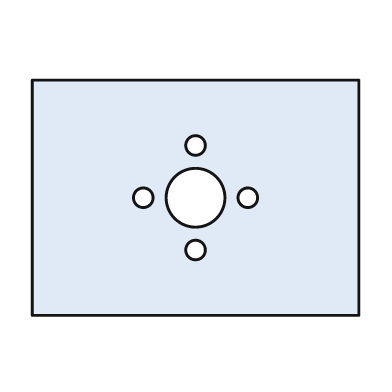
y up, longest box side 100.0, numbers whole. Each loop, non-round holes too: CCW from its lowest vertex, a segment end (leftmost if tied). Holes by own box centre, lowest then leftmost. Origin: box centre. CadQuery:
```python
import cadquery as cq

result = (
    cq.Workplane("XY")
    .moveTo(-50.0, -36.0)
    .lineTo(50.0, -36.0)
    .lineTo(50.0, 36.0)
    .lineTo(-50.0, 36.0)
    .close()
    .moveTo(0.0, -16.0)
    .circle(3.0)
    .moveTo(-16.0, 0.0)
    .circle(3.0)
    .moveTo(0.0, 0.0)
    .circle(9.0)
    .moveTo(16.0, 0.0)
    .circle(3.0)
    .moveTo(0.0, 16.0)
    .circle(3.0)
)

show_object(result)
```